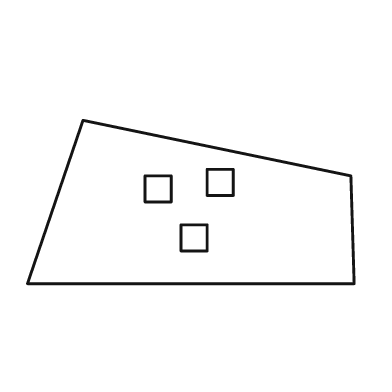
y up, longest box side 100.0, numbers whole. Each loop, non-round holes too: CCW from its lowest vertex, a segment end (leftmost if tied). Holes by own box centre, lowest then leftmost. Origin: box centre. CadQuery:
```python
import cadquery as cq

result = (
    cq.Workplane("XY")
    .moveTo(-50.0, -25.0)
    .lineTo(50.0, -25.0)
    .lineTo(49.0, 8.0)
    .lineTo(-33.0, 25.0)
    .close()
    .moveTo(-3.0, -15.0)
    .lineTo(5.0, -15.0)
    .lineTo(5.0, -7.0)
    .lineTo(-3.0, -7.0)
    .close()
    .moveTo(-14.0, 0.0)
    .lineTo(-6.0, 0.0)
    .lineTo(-6.0, 8.0)
    .lineTo(-14.0, 8.0)
    .close()
    .moveTo(5.0, 2.0)
    .lineTo(13.0, 2.0)
    .lineTo(13.0, 10.0)
    .lineTo(5.0, 10.0)
    .close()
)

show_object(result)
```